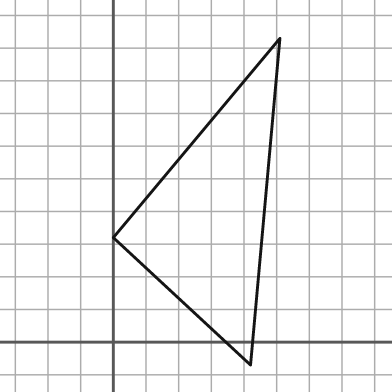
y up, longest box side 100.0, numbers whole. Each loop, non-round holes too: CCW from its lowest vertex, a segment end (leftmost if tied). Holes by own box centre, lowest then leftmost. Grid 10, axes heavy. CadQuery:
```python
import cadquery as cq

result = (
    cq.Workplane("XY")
    .moveTo(42.0, -7.0)
    .lineTo(51.0, 93.0)
    .lineTo(0.0, 32.0)
    .close()
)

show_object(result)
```